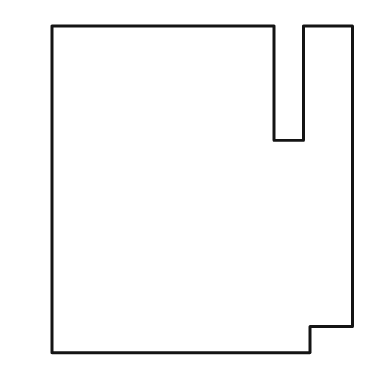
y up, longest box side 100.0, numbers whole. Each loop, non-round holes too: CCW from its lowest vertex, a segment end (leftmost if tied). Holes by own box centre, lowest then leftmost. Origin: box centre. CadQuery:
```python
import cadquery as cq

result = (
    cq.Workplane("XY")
    .moveTo(-46.0, -50.0)
    .lineTo(33.0, -50.0)
    .lineTo(33.0, -42.0)
    .lineTo(46.0, -42.0)
    .lineTo(46.0, 50.0)
    .lineTo(31.0, 50.0)
    .lineTo(31.0, 15.0)
    .lineTo(22.0, 15.0)
    .lineTo(22.0, 50.0)
    .lineTo(-46.0, 50.0)
    .close()
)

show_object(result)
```